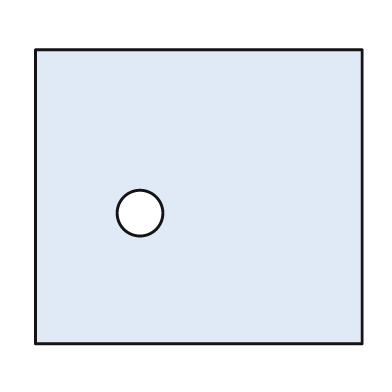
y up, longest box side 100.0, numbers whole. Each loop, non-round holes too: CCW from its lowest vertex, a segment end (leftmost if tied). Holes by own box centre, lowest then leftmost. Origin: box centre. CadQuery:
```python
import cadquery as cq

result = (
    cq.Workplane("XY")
    .moveTo(-50.0, -45.0)
    .lineTo(50.0, -45.0)
    .lineTo(50.0, 45.0)
    .lineTo(-50.0, 45.0)
    .close()
    .moveTo(-18.0, -5.0)
    .circle(7.0)
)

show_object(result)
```